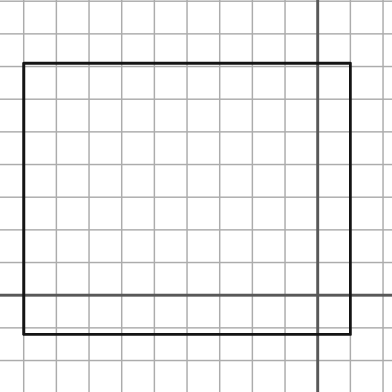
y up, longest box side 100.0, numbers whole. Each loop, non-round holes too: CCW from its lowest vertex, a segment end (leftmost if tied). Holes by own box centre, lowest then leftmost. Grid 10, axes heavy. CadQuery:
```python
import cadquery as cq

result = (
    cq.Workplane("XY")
    .moveTo(-90.0, -12.0)
    .lineTo(10.0, -12.0)
    .lineTo(10.0, 71.0)
    .lineTo(-90.0, 71.0)
    .close()
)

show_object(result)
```